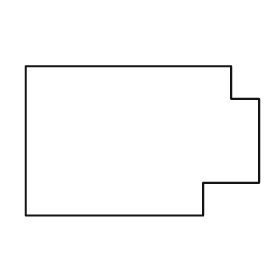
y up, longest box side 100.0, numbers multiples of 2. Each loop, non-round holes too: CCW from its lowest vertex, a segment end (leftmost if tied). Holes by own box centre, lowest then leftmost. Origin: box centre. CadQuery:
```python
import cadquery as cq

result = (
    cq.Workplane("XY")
    .moveTo(-50.0, -32.0)
    .lineTo(26.0, -32.0)
    .lineTo(26.0, -18.0)
    .lineTo(50.0, -18.0)
    .lineTo(50.0, 18.0)
    .lineTo(38.0, 18.0)
    .lineTo(38.0, 32.0)
    .lineTo(-50.0, 32.0)
    .close()
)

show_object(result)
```